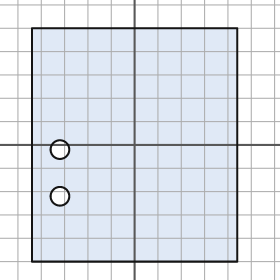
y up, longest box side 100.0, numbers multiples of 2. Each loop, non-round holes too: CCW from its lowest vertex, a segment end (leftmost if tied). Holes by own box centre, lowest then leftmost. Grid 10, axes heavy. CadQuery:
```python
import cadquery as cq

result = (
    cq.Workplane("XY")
    .moveTo(-44.0, -50.0)
    .lineTo(44.0, -50.0)
    .lineTo(44.0, 50.0)
    .lineTo(-44.0, 50.0)
    .close()
    .moveTo(-32.0, -22.0)
    .circle(4.0)
    .moveTo(-32.0, -2.0)
    .circle(4.0)
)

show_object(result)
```